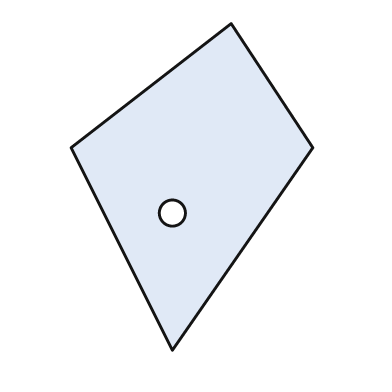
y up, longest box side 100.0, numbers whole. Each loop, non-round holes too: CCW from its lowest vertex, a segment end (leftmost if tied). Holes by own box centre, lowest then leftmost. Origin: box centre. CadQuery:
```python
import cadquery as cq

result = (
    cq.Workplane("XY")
    .moveTo(-6.0, -50.0)
    .lineTo(37.0, 12.0)
    .lineTo(12.0, 50.0)
    .lineTo(-37.0, 12.0)
    .close()
    .moveTo(-6.0, -8.0)
    .circle(4.0)
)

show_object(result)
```